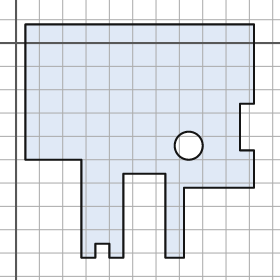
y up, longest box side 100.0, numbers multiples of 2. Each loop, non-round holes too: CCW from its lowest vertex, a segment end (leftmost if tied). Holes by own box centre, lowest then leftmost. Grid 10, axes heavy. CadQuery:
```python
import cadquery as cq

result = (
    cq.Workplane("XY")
    .moveTo(28.0, -92.0)
    .lineTo(34.0, -92.0)
    .lineTo(34.0, -86.0)
    .lineTo(40.0, -86.0)
    .lineTo(40.0, -92.0)
    .lineTo(46.0, -92.0)
    .lineTo(46.0, -56.0)
    .lineTo(64.0, -56.0)
    .lineTo(64.0, -92.0)
    .lineTo(72.0, -92.0)
    .lineTo(72.0, -62.0)
    .lineTo(102.0, -62.0)
    .lineTo(102.0, -46.0)
    .lineTo(96.0, -46.0)
    .lineTo(96.0, -26.0)
    .lineTo(102.0, -26.0)
    .lineTo(102.0, 8.0)
    .lineTo(4.0, 8.0)
    .lineTo(4.0, -50.0)
    .lineTo(28.0, -50.0)
    .close()
    .moveTo(74.0, -44.0)
    .circle(6.0)
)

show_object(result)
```